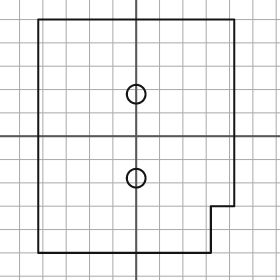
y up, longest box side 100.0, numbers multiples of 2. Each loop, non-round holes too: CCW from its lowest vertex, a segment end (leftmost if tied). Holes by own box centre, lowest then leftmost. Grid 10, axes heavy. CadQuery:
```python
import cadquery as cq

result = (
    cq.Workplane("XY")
    .moveTo(-42.0, -50.0)
    .lineTo(32.0, -50.0)
    .lineTo(32.0, -30.0)
    .lineTo(42.0, -30.0)
    .lineTo(42.0, 50.0)
    .lineTo(-42.0, 50.0)
    .close()
    .moveTo(0.0, -18.0)
    .circle(4.0)
    .moveTo(0.0, 18.0)
    .circle(4.0)
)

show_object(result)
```